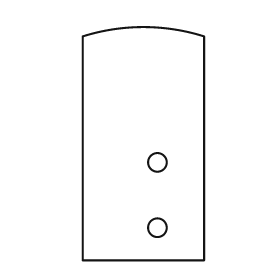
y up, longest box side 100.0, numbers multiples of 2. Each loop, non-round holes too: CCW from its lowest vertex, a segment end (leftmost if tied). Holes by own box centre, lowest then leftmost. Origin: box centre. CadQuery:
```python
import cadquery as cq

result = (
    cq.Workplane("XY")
    .moveTo(-26.0, -50.0)
    .lineTo(26.0, -50.0)
    .lineTo(26.0, 46.0)
    .threePointArc((0.0, 50.0), (-26.0, 46.0))
    .close()
    .moveTo(6.0, -36.0)
    .circle(4.0)
    .moveTo(6.0, -8.0)
    .circle(4.0)
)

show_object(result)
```